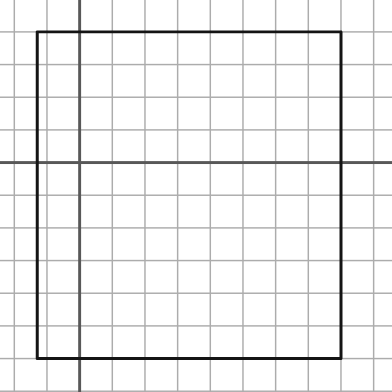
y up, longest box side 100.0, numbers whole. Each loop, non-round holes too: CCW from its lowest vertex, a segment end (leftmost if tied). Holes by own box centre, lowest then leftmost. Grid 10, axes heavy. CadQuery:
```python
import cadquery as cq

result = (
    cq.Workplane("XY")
    .moveTo(-13.0, -60.0)
    .lineTo(80.0, -60.0)
    .lineTo(80.0, 40.0)
    .lineTo(-13.0, 40.0)
    .close()
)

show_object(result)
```